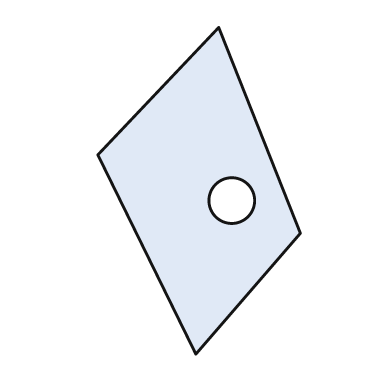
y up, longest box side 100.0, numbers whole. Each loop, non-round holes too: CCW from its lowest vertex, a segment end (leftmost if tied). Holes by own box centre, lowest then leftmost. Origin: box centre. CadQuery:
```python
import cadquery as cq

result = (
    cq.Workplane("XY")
    .moveTo(-1.0, -50.0)
    .lineTo(31.0, -13.0)
    .lineTo(6.0, 50.0)
    .lineTo(-31.0, 11.0)
    .close()
    .moveTo(10.0, -3.0)
    .circle(7.0)
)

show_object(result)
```